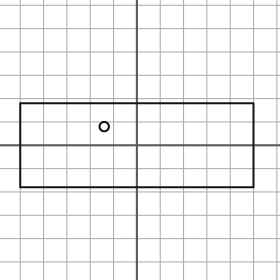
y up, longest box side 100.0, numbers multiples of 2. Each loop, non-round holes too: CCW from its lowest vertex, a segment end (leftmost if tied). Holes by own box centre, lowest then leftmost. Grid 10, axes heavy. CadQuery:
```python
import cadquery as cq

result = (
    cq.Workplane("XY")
    .moveTo(-50.0, -18.0)
    .lineTo(50.0, -18.0)
    .lineTo(50.0, 18.0)
    .lineTo(-50.0, 18.0)
    .close()
    .moveTo(-14.0, 8.0)
    .circle(2.0)
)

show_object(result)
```